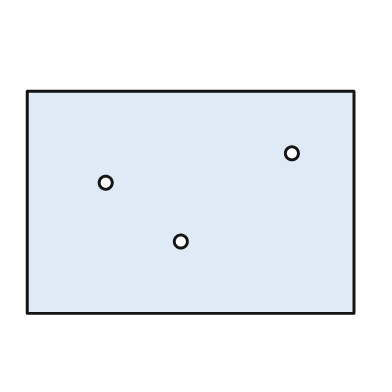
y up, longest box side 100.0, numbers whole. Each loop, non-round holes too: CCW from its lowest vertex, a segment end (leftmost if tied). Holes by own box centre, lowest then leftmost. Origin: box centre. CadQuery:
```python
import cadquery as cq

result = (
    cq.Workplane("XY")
    .moveTo(-50.0, -34.0)
    .lineTo(50.0, -34.0)
    .lineTo(50.0, 34.0)
    .lineTo(-50.0, 34.0)
    .close()
    .moveTo(-3.0, -12.0)
    .circle(2.0)
    .moveTo(-26.0, 6.0)
    .circle(2.0)
    .moveTo(31.0, 15.0)
    .circle(2.0)
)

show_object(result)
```